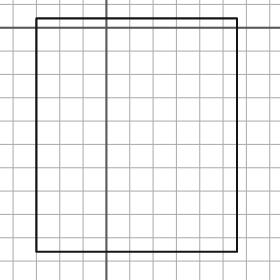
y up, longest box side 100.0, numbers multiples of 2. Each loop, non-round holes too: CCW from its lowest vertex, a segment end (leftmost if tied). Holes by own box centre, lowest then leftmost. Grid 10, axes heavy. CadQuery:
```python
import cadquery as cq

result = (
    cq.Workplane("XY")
    .moveTo(-30.0, -96.0)
    .lineTo(56.0, -96.0)
    .lineTo(56.0, 4.0)
    .lineTo(-30.0, 4.0)
    .close()
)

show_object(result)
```